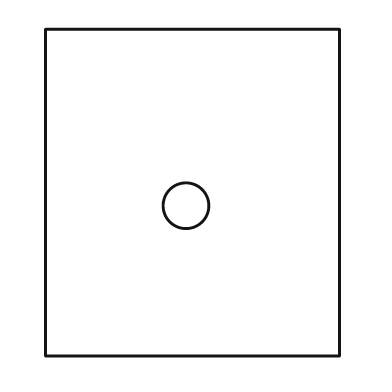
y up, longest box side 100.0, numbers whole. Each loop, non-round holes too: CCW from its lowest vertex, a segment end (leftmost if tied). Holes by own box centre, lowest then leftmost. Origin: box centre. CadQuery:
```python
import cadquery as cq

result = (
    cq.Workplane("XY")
    .moveTo(-45.0, -50.0)
    .lineTo(45.0, -50.0)
    .lineTo(45.0, 50.0)
    .lineTo(-45.0, 50.0)
    .close()
    .moveTo(-2.0, -4.0)
    .circle(7.0)
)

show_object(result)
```